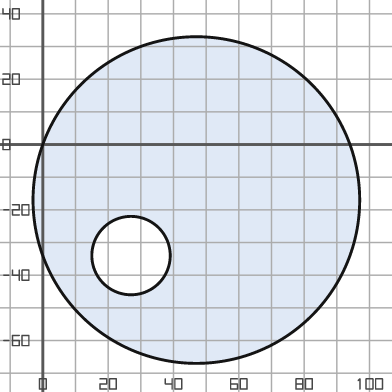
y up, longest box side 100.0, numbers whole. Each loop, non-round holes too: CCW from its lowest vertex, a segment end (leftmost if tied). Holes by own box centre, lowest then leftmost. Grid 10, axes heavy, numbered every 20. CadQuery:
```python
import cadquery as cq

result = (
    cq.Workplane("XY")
    .moveTo(47.0, -17.0)
    .circle(50.0)
    .moveTo(27.0, -34.0)
    .circle(12.0)
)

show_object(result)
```